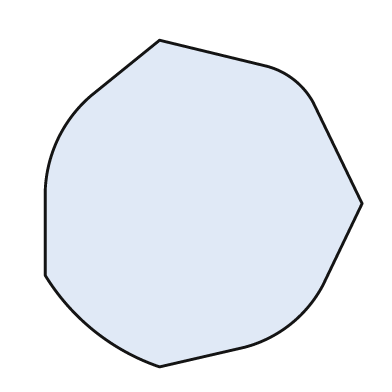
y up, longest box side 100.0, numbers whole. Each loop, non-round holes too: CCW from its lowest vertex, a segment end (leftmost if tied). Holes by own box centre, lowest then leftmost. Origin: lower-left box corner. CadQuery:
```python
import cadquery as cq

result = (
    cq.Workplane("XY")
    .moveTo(35.0, 0.0)
    .lineTo(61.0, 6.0)
    .threePointArc((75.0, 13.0), (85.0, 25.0))
    .lineTo(97.0, 50.0)
    .lineTo(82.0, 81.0)
    .threePointArc((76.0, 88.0), (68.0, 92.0))
    .lineTo(35.0, 100.0)
    .lineTo(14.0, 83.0)
    .threePointArc((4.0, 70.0), (0.0, 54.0))
    .lineTo(0.0, 28.0)
    .threePointArc((15.0, 11.0), (35.0, 0.0))
    .close()
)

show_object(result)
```